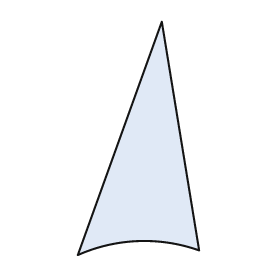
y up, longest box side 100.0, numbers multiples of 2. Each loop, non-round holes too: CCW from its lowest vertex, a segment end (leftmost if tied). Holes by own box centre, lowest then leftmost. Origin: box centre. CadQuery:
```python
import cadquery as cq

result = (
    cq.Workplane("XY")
    .moveTo(-26.0, -50.0)
    .threePointArc((0.0, -44.0), (26.0, -48.0))
    .lineTo(10.0, 50.0)
    .close()
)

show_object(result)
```